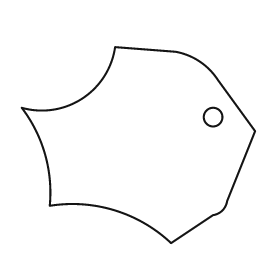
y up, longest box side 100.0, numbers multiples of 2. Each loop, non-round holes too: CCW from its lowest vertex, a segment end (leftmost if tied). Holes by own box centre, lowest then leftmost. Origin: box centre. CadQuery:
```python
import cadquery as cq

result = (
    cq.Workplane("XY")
    .moveTo(14.0, -42.0)
    .lineTo(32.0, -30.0)
    .threePointArc((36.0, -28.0), (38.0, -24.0))
    .lineTo(50.0, 6.0)
    .lineTo(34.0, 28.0)
    .threePointArc((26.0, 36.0), (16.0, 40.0))
    .lineTo(-10.0, 42.0)
    .threePointArc((-24.0, 20.0), (-50.0, 16.0))
    .threePointArc((-40.0, -4.0), (-38.0, -26.0))
    .threePointArc((-10.0, -28.0), (14.0, -42.0))
    .close()
    .moveTo(32.0, 12.0)
    .circle(4.0)
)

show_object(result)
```